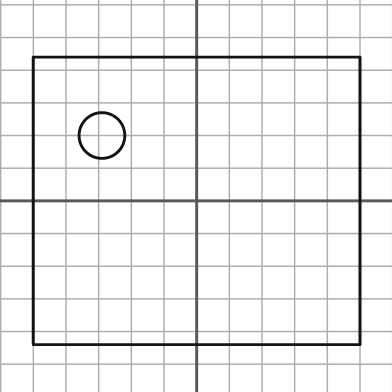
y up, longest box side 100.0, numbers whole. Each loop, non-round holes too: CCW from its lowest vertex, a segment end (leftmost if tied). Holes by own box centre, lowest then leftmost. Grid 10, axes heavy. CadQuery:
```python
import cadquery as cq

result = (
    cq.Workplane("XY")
    .moveTo(-50.0, -44.0)
    .lineTo(50.0, -44.0)
    .lineTo(50.0, 44.0)
    .lineTo(-50.0, 44.0)
    .close()
    .moveTo(-29.0, 20.0)
    .circle(7.0)
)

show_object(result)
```